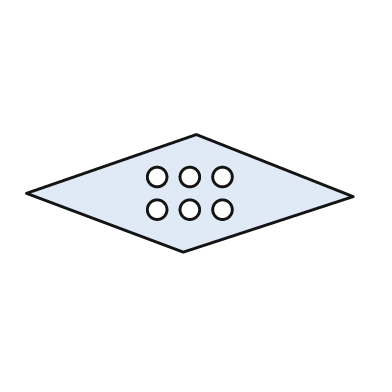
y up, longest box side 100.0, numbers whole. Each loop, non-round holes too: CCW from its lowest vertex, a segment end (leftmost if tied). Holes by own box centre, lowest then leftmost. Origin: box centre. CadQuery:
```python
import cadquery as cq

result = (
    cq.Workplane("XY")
    .moveTo(-2.0, -18.0)
    .lineTo(50.0, -1.0)
    .lineTo(2.0, 18.0)
    .lineTo(-50.0, 0.0)
    .close()
    .moveTo(-10.0, -5.0)
    .circle(3.0)
    .moveTo(0.0, -5.0)
    .circle(3.0)
    .moveTo(10.0, -5.0)
    .circle(3.0)
    .moveTo(-10.0, 5.0)
    .circle(3.0)
    .moveTo(0.0, 5.0)
    .circle(3.0)
    .moveTo(10.0, 5.0)
    .circle(3.0)
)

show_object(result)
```